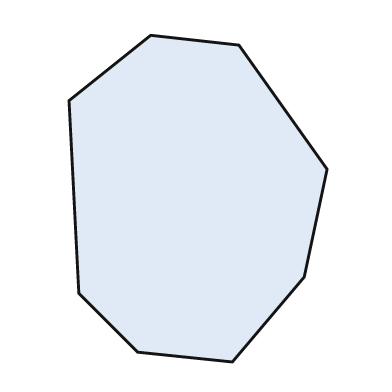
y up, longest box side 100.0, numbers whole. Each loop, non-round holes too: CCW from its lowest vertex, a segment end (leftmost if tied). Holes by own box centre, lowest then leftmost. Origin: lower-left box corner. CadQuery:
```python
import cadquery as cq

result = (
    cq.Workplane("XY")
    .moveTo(50.0, 0.0)
    .lineTo(72.0, 26.0)
    .lineTo(79.0, 59.0)
    .lineTo(52.0, 97.0)
    .lineTo(25.0, 100.0)
    .lineTo(0.0, 80.0)
    .lineTo(3.0, 21.0)
    .lineTo(21.0, 3.0)
    .close()
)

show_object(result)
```